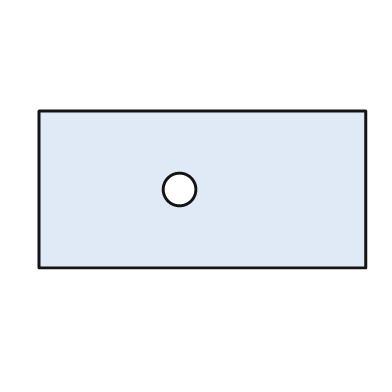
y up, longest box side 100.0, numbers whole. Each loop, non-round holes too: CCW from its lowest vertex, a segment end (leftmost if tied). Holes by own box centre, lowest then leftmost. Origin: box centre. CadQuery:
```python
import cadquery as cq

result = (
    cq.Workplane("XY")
    .moveTo(-50.0, -24.0)
    .lineTo(50.0, -24.0)
    .lineTo(50.0, 24.0)
    .lineTo(-50.0, 24.0)
    .close()
    .moveTo(-7.0, 0.0)
    .circle(5.0)
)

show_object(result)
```